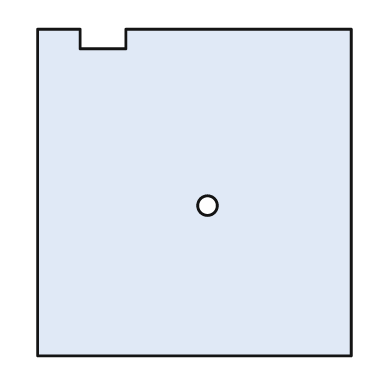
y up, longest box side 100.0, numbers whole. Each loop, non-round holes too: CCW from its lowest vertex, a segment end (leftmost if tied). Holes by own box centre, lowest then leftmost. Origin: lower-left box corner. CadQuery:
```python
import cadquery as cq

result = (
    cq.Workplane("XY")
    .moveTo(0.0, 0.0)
    .lineTo(96.0, 0.0)
    .lineTo(96.0, 100.0)
    .lineTo(27.0, 100.0)
    .lineTo(27.0, 94.0)
    .lineTo(13.0, 94.0)
    .lineTo(13.0, 100.0)
    .lineTo(0.0, 100.0)
    .close()
    .moveTo(52.0, 46.0)
    .circle(3.0)
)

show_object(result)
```